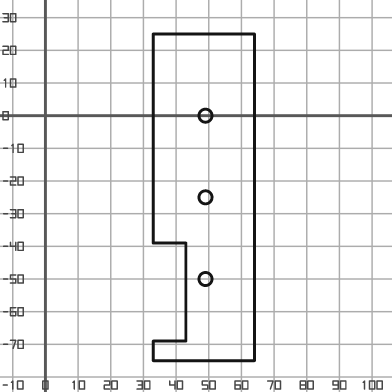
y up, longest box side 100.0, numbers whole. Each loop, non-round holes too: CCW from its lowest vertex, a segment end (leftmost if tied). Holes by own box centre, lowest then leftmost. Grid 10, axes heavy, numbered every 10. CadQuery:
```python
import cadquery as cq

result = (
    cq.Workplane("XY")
    .moveTo(33.0, -75.0)
    .lineTo(64.0, -75.0)
    .lineTo(64.0, 25.0)
    .lineTo(33.0, 25.0)
    .lineTo(33.0, -39.0)
    .lineTo(43.0, -39.0)
    .lineTo(43.0, -69.0)
    .lineTo(33.0, -69.0)
    .close()
    .moveTo(49.0, -50.0)
    .circle(2.0)
    .moveTo(49.0, -25.0)
    .circle(2.0)
    .moveTo(49.0, 0.0)
    .circle(2.0)
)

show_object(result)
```